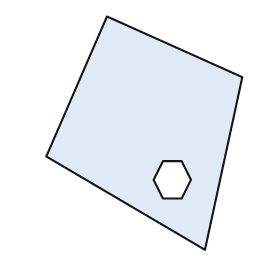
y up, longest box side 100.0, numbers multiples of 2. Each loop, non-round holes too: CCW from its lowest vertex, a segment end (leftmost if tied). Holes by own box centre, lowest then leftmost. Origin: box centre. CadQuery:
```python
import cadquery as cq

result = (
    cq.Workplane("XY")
    .moveTo(26.0, -50.0)
    .lineTo(42.0, 24.0)
    .lineTo(-16.0, 50.0)
    .lineTo(-42.0, -10.0)
    .close()
    .moveTo(8.0, -28.0)
    .lineTo(16.0, -28.0)
    .lineTo(20.0, -20.0)
    .lineTo(16.0, -12.0)
    .lineTo(8.0, -12.0)
    .lineTo(4.0, -20.0)
    .close()
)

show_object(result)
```